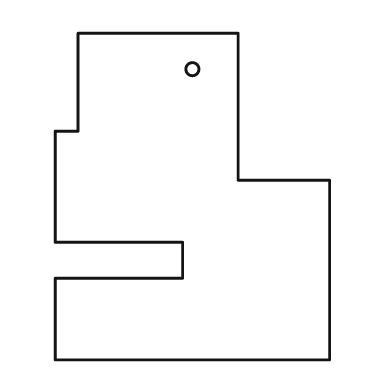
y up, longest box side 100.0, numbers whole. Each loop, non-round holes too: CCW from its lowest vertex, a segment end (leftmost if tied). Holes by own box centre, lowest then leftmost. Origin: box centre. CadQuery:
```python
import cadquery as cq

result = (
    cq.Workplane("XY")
    .moveTo(-42.0, -50.0)
    .lineTo(42.0, -50.0)
    .lineTo(42.0, 5.0)
    .lineTo(14.0, 5.0)
    .lineTo(14.0, 50.0)
    .lineTo(-35.0, 50.0)
    .lineTo(-35.0, 20.0)
    .lineTo(-42.0, 20.0)
    .lineTo(-42.0, -14.0)
    .lineTo(-3.0, -14.0)
    .lineTo(-3.0, -25.0)
    .lineTo(-42.0, -25.0)
    .close()
    .moveTo(0.0, 39.0)
    .circle(2.0)
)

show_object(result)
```